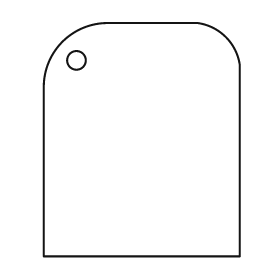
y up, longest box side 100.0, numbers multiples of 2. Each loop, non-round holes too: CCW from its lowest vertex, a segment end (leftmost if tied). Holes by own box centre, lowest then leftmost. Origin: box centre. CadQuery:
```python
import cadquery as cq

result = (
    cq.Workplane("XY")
    .moveTo(-42.0, -50.0)
    .lineTo(42.0, -50.0)
    .lineTo(42.0, 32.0)
    .threePointArc((36.0, 44.0), (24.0, 50.0))
    .lineTo(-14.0, 50.0)
    .threePointArc((-34.0, 42.0), (-42.0, 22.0))
    .close()
    .moveTo(-28.0, 34.0)
    .circle(4.0)
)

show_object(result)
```